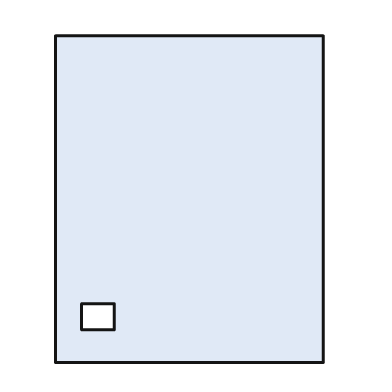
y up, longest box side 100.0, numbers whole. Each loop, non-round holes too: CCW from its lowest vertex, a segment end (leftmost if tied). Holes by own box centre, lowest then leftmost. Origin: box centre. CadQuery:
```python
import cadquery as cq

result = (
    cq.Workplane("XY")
    .moveTo(-41.0, -50.0)
    .lineTo(41.0, -50.0)
    .lineTo(41.0, 50.0)
    .lineTo(-41.0, 50.0)
    .close()
    .moveTo(-33.0, -40.0)
    .lineTo(-23.0, -40.0)
    .lineTo(-23.0, -32.0)
    .lineTo(-33.0, -32.0)
    .close()
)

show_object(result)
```